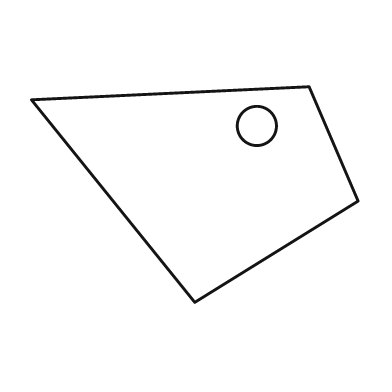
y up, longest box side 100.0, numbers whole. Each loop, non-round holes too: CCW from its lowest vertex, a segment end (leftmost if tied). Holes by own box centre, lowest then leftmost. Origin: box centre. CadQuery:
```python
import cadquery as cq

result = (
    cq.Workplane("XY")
    .moveTo(0.0, -33.0)
    .lineTo(50.0, -2.0)
    .lineTo(35.0, 33.0)
    .lineTo(-50.0, 29.0)
    .close()
    .moveTo(19.0, 21.0)
    .circle(6.0)
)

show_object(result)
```